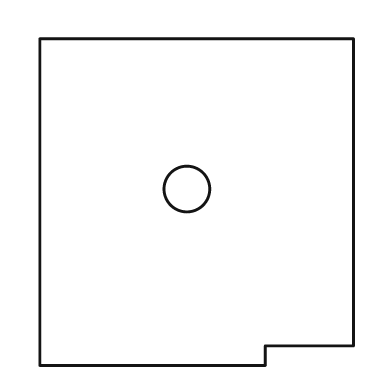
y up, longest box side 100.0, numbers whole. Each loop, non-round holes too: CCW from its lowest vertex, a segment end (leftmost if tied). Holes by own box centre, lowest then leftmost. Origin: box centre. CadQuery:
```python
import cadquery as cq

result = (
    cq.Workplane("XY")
    .moveTo(-48.0, -50.0)
    .lineTo(21.0, -50.0)
    .lineTo(21.0, -44.0)
    .lineTo(48.0, -44.0)
    .lineTo(48.0, 50.0)
    .lineTo(-48.0, 50.0)
    .close()
    .moveTo(-3.0, 4.0)
    .circle(7.0)
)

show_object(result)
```